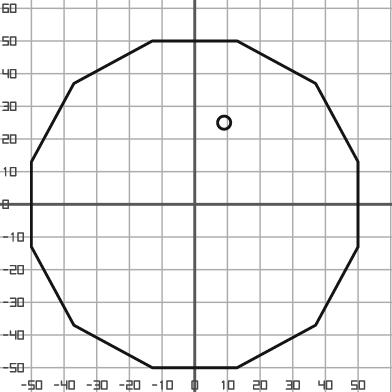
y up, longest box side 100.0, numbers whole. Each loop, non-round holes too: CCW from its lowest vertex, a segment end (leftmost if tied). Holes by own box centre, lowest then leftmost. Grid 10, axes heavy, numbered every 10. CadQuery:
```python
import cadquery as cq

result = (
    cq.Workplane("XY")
    .moveTo(-13.0, -50.0)
    .lineTo(13.0, -50.0)
    .lineTo(37.0, -37.0)
    .lineTo(50.0, -13.0)
    .lineTo(50.0, 13.0)
    .lineTo(37.0, 37.0)
    .lineTo(13.0, 50.0)
    .lineTo(-13.0, 50.0)
    .lineTo(-37.0, 37.0)
    .lineTo(-50.0, 13.0)
    .lineTo(-50.0, -13.0)
    .lineTo(-37.0, -37.0)
    .close()
    .moveTo(9.0, 25.0)
    .circle(2.0)
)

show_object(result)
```